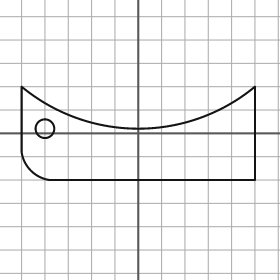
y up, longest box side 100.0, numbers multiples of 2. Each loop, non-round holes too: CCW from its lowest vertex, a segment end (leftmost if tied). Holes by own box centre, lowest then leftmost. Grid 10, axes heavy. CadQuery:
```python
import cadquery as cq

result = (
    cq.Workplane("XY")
    .moveTo(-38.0, -20.0)
    .lineTo(50.0, -20.0)
    .lineTo(50.0, 20.0)
    .threePointArc((0.0, 2.0), (-50.0, 20.0))
    .lineTo(-50.0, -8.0)
    .threePointArc((-46.0, -16.0), (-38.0, -20.0))
    .close()
    .moveTo(-40.0, 2.0)
    .circle(4.0)
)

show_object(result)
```